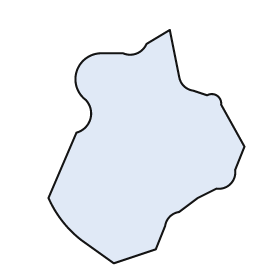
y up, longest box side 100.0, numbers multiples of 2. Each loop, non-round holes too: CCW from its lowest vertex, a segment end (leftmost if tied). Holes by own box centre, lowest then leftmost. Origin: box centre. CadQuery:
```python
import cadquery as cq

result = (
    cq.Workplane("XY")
    .moveTo(-14.0, -50.0)
    .lineTo(4.0, -44.0)
    .lineTo(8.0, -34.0)
    .threePointArc((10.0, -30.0), (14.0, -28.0))
    .lineTo(22.0, -22.0)
    .lineTo(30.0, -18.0)
    .threePointArc((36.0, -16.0), (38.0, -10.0))
    .lineTo(42.0, 0.0)
    .lineTo(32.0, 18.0)
    .threePointArc((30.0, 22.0), (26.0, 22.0))
    .lineTo(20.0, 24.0)
    .threePointArc((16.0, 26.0), (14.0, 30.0))
    .lineTo(10.0, 50.0)
    .lineTo(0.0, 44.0)
    .threePointArc((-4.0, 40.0), (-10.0, 40.0))
    .lineTo(-20.0, 40.0)
    .threePointArc((-30.0, 32.0), (-26.0, 20.0))
    .threePointArc((-24.0, 12.0), (-30.0, 6.0))
    .lineTo(-42.0, -22.0)
    .threePointArc((-36.0, -32.0), (-28.0, -40.0))
    .close()
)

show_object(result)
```